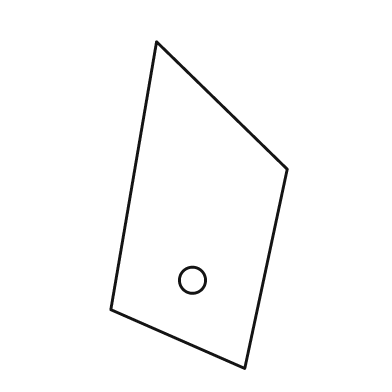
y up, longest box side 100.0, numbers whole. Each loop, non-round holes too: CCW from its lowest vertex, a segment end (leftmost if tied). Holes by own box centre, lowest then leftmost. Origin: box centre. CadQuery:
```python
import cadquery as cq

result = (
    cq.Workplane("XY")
    .moveTo(14.0, -50.0)
    .lineTo(27.0, 11.0)
    .lineTo(-13.0, 50.0)
    .lineTo(-27.0, -32.0)
    .close()
    .moveTo(-2.0, -23.0)
    .circle(4.0)
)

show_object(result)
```